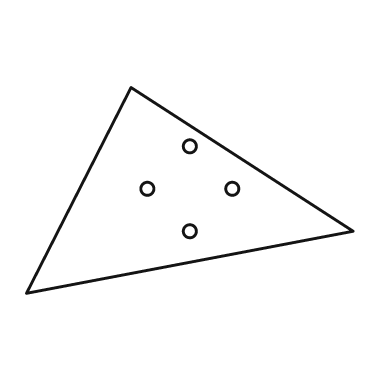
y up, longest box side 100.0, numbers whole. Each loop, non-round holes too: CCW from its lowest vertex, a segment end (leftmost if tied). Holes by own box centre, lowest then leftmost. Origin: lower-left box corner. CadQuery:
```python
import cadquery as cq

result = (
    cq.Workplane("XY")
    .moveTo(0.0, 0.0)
    .lineTo(100.0, 19.0)
    .lineTo(32.0, 63.0)
    .close()
    .moveTo(50.0, 19.0)
    .circle(2.0)
    .moveTo(37.0, 32.0)
    .circle(2.0)
    .moveTo(63.0, 32.0)
    .circle(2.0)
    .moveTo(50.0, 45.0)
    .circle(2.0)
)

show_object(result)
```